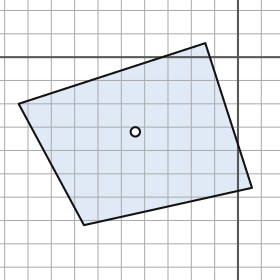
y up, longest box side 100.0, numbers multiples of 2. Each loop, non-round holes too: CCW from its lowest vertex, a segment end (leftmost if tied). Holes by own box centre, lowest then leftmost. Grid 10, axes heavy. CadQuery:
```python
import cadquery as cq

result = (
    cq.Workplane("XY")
    .moveTo(-66.0, -72.0)
    .lineTo(6.0, -56.0)
    .lineTo(-14.0, 6.0)
    .lineTo(-94.0, -20.0)
    .close()
    .moveTo(-44.0, -32.0)
    .circle(2.0)
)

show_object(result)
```